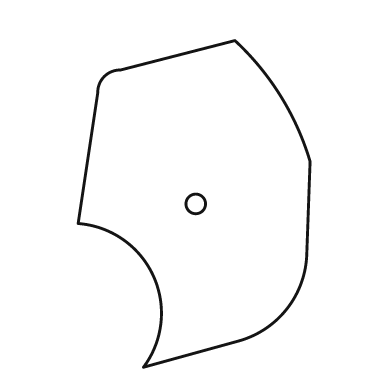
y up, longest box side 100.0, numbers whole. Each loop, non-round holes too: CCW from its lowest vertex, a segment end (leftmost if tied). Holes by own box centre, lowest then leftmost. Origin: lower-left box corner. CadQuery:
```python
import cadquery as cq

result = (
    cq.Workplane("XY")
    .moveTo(20.0, 0.0)
    .lineTo(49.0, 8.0)
    .threePointArc((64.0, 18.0), (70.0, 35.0))
    .lineTo(71.0, 63.0)
    .threePointArc((62.0, 83.0), (48.0, 100.0))
    .lineTo(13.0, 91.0)
    .threePointArc((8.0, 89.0), (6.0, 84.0))
    .lineTo(0.0, 44.0)
    .threePointArc((23.0, 28.0), (20.0, 0.0))
    .close()
    .moveTo(36.0, 50.0)
    .circle(3.0)
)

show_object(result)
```